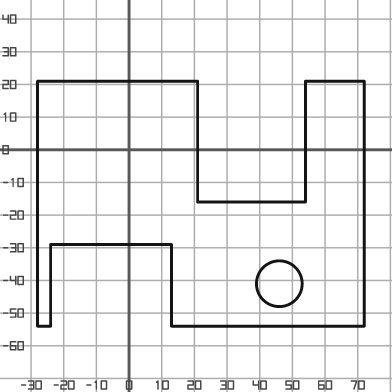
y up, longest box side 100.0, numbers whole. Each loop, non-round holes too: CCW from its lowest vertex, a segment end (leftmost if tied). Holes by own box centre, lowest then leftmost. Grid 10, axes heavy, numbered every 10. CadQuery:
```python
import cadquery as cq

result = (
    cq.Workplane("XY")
    .moveTo(-28.0, -54.0)
    .lineTo(-24.0, -54.0)
    .lineTo(-24.0, -29.0)
    .lineTo(13.0, -29.0)
    .lineTo(13.0, -54.0)
    .lineTo(72.0, -54.0)
    .lineTo(72.0, 21.0)
    .lineTo(54.0, 21.0)
    .lineTo(54.0, -16.0)
    .lineTo(21.0, -16.0)
    .lineTo(21.0, 21.0)
    .lineTo(-28.0, 21.0)
    .close()
    .moveTo(46.0, -41.0)
    .circle(7.0)
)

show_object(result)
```